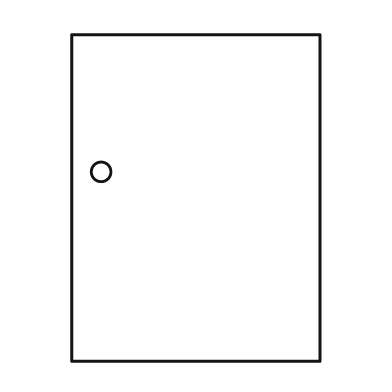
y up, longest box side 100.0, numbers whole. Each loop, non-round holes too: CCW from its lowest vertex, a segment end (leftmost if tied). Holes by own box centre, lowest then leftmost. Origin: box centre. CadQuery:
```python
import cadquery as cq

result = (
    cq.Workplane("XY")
    .moveTo(-38.0, -50.0)
    .lineTo(38.0, -50.0)
    .lineTo(38.0, 50.0)
    .lineTo(-38.0, 50.0)
    .close()
    .moveTo(-29.0, 8.0)
    .circle(3.0)
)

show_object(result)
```